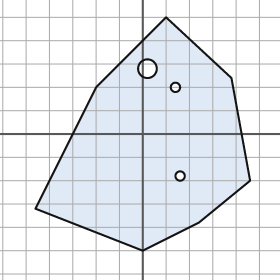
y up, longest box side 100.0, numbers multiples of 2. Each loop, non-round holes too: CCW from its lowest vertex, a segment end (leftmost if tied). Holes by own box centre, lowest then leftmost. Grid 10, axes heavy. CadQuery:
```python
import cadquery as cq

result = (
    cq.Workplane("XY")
    .moveTo(0.0, -50.0)
    .lineTo(24.0, -38.0)
    .lineTo(46.0, -20.0)
    .lineTo(38.0, 24.0)
    .lineTo(10.0, 50.0)
    .lineTo(-20.0, 20.0)
    .lineTo(-46.0, -32.0)
    .close()
    .moveTo(16.0, -18.0)
    .circle(2.0)
    .moveTo(14.0, 20.0)
    .circle(2.0)
    .moveTo(2.0, 28.0)
    .circle(4.0)
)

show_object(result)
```